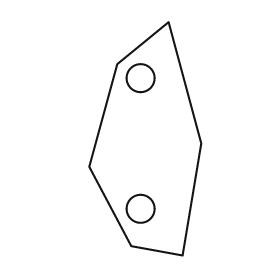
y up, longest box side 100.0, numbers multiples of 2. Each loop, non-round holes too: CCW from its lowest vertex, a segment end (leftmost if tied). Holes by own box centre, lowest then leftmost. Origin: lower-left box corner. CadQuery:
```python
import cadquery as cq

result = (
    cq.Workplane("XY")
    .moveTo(40.0, 0.0)
    .lineTo(48.0, 48.0)
    .lineTo(34.0, 100.0)
    .lineTo(12.0, 82.0)
    .lineTo(0.0, 38.0)
    .lineTo(18.0, 4.0)
    .close()
    .moveTo(22.0, 20.0)
    .circle(6.0)
    .moveTo(22.0, 76.0)
    .circle(6.0)
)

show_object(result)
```